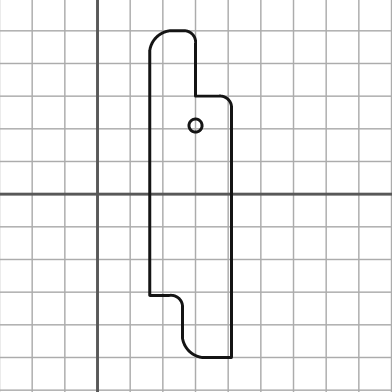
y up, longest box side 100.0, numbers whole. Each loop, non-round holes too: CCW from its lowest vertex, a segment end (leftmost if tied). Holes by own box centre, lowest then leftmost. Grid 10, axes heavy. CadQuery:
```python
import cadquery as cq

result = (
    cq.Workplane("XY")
    .moveTo(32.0, -50.0)
    .lineTo(41.0, -50.0)
    .lineTo(41.0, 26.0)
    .threePointArc((40.0, 29.0), (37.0, 30.0))
    .lineTo(30.0, 30.0)
    .lineTo(30.0, 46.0)
    .threePointArc((29.0, 49.0), (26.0, 50.0))
    .lineTo(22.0, 50.0)
    .threePointArc((18.0, 48.0), (16.0, 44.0))
    .lineTo(16.0, -31.0)
    .lineTo(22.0, -31.0)
    .threePointArc((25.0, -32.0), (26.0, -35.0))
    .lineTo(26.0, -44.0)
    .threePointArc((28.0, -48.0), (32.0, -50.0))
    .close()
    .moveTo(30.0, 21.0)
    .circle(2.0)
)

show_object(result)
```